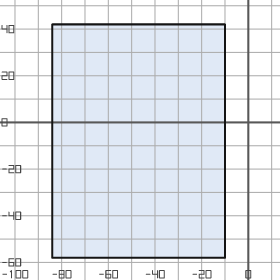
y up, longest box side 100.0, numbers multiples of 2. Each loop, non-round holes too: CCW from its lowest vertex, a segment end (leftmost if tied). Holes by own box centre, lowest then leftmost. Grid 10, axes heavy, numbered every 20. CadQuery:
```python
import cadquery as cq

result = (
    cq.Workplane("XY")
    .moveTo(-84.0, -58.0)
    .lineTo(-10.0, -58.0)
    .lineTo(-10.0, 42.0)
    .lineTo(-84.0, 42.0)
    .close()
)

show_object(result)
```